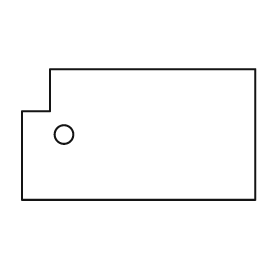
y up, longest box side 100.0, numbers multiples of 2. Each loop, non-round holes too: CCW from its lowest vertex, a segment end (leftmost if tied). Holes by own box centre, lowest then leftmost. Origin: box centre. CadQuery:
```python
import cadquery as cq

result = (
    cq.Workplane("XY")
    .moveTo(-50.0, -28.0)
    .lineTo(50.0, -28.0)
    .lineTo(50.0, 28.0)
    .lineTo(-38.0, 28.0)
    .lineTo(-38.0, 10.0)
    .lineTo(-50.0, 10.0)
    .close()
    .moveTo(-32.0, 0.0)
    .circle(4.0)
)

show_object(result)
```